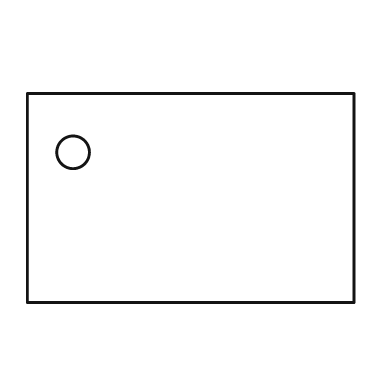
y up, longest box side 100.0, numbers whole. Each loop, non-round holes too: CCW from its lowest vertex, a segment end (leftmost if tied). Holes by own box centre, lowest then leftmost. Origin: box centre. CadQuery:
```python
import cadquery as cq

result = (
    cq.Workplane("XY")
    .moveTo(-50.0, -32.0)
    .lineTo(50.0, -32.0)
    .lineTo(50.0, 32.0)
    .lineTo(-50.0, 32.0)
    .close()
    .moveTo(-36.0, 14.0)
    .circle(5.0)
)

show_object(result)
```